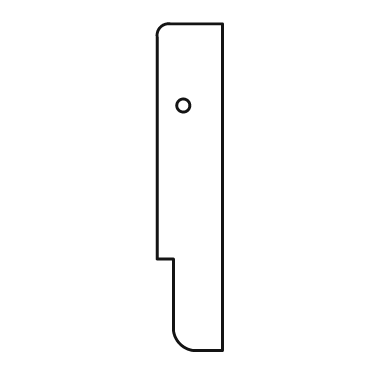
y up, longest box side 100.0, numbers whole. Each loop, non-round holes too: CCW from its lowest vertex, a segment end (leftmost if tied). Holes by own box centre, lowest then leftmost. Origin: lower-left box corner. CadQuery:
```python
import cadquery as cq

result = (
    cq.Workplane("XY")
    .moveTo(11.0, 0.0)
    .lineTo(20.0, 0.0)
    .lineTo(20.0, 100.0)
    .lineTo(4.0, 100.0)
    .threePointArc((1.0, 99.0), (0.0, 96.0))
    .lineTo(0.0, 28.0)
    .lineTo(5.0, 28.0)
    .lineTo(5.0, 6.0)
    .threePointArc((7.0, 2.0), (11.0, 0.0))
    .close()
    .moveTo(8.0, 75.0)
    .circle(2.0)
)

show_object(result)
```